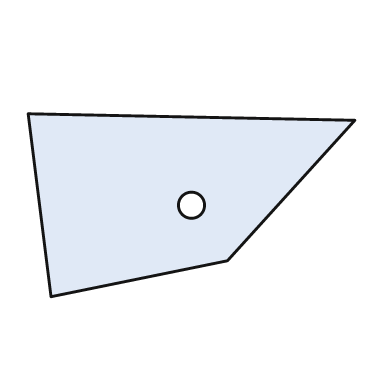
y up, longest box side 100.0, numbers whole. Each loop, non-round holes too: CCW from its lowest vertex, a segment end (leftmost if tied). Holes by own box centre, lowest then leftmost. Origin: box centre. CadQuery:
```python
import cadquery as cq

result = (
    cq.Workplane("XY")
    .moveTo(-43.0, -28.0)
    .lineTo(11.0, -17.0)
    .lineTo(50.0, 26.0)
    .lineTo(-50.0, 28.0)
    .close()
    .moveTo(0.0, 0.0)
    .circle(4.0)
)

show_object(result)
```